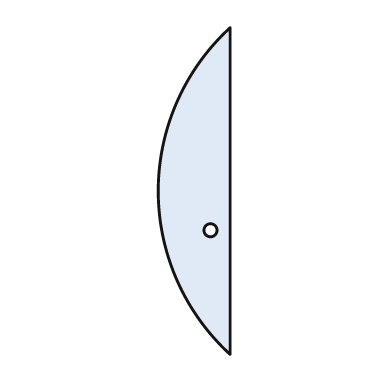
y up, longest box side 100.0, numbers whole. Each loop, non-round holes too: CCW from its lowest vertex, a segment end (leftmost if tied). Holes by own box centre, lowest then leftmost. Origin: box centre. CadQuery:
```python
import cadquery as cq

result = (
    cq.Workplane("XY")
    .moveTo(11.0, -50.0)
    .lineTo(11.0, 50.0)
    .threePointArc((-11.0, 0.0), (11.0, -50.0))
    .close()
    .moveTo(5.0, -12.0)
    .circle(2.0)
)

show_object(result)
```